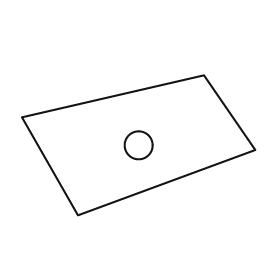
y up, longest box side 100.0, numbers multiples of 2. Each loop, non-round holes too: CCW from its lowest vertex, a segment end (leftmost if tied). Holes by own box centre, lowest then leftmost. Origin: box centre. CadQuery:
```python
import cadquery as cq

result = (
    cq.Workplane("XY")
    .moveTo(-26.0, -30.0)
    .lineTo(50.0, -2.0)
    .lineTo(28.0, 30.0)
    .lineTo(-50.0, 12.0)
    .close()
    .moveTo(0.0, 0.0)
    .circle(6.0)
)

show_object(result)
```